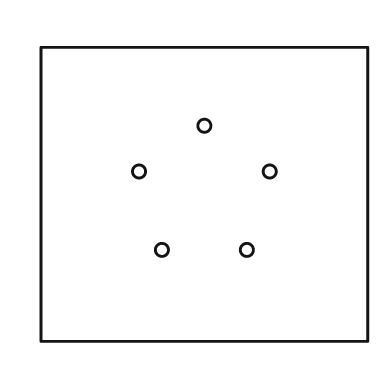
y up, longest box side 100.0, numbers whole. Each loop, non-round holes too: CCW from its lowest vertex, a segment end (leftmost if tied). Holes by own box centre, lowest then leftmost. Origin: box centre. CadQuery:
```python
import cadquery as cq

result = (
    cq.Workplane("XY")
    .moveTo(-50.0, -45.0)
    .lineTo(50.0, -45.0)
    .lineTo(50.0, 45.0)
    .lineTo(-50.0, 45.0)
    .close()
    .moveTo(-13.0, -17.0)
    .circle(2.0)
    .moveTo(13.0, -17.0)
    .circle(2.0)
    .moveTo(-20.0, 7.0)
    .circle(2.0)
    .moveTo(20.0, 7.0)
    .circle(2.0)
    .moveTo(0.0, 21.0)
    .circle(2.0)
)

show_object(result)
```